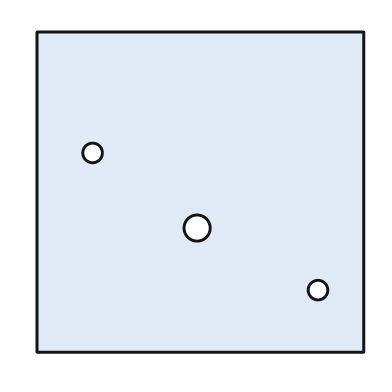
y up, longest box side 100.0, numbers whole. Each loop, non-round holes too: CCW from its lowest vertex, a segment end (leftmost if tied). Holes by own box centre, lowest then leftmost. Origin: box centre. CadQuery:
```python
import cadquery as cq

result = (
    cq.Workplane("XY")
    .moveTo(-50.0, -49.0)
    .lineTo(50.0, -49.0)
    .lineTo(50.0, 49.0)
    .lineTo(-50.0, 49.0)
    .close()
    .moveTo(36.0, -30.0)
    .circle(3.0)
    .moveTo(-1.0, -11.0)
    .circle(4.0)
    .moveTo(-33.0, 12.0)
    .circle(3.0)
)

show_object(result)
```